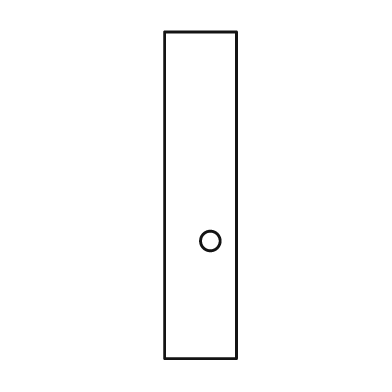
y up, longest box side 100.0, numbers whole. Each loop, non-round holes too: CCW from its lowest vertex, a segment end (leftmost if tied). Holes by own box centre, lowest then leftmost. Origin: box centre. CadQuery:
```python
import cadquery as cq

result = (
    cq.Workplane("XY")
    .moveTo(-11.0, -50.0)
    .lineTo(11.0, -50.0)
    .lineTo(11.0, 50.0)
    .lineTo(-11.0, 50.0)
    .close()
    .moveTo(3.0, -14.0)
    .circle(3.0)
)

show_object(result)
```